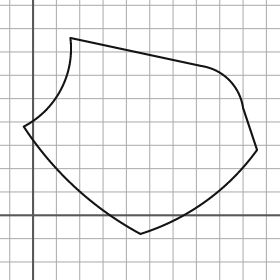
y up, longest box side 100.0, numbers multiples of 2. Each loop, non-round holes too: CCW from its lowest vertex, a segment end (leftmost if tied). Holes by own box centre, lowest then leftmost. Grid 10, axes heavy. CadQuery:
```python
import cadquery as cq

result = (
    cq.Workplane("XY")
    .moveTo(46.0, -8.0)
    .threePointArc((74.0, 6.0), (96.0, 28.0))
    .lineTo(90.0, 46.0)
    .threePointArc((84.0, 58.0), (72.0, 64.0))
    .lineTo(16.0, 76.0)
    .threePointArc((12.0, 54.0), (-4.0, 38.0))
    .threePointArc((18.0, 12.0), (46.0, -8.0))
    .close()
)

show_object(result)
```